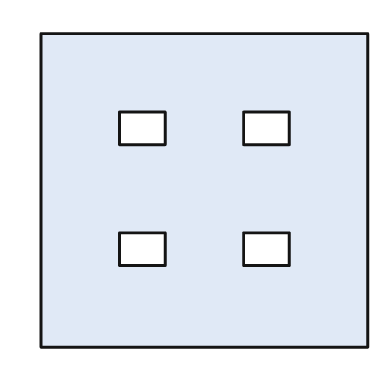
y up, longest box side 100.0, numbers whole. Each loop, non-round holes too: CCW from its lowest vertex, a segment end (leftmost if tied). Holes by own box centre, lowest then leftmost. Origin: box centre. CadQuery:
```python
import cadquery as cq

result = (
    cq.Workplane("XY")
    .moveTo(-50.0, -48.0)
    .lineTo(50.0, -48.0)
    .lineTo(50.0, 48.0)
    .lineTo(-50.0, 48.0)
    .close()
    .moveTo(-26.0, -23.0)
    .lineTo(-12.0, -23.0)
    .lineTo(-12.0, -13.0)
    .lineTo(-26.0, -13.0)
    .close()
    .moveTo(12.0, -23.0)
    .lineTo(26.0, -23.0)
    .lineTo(26.0, -13.0)
    .lineTo(12.0, -13.0)
    .close()
    .moveTo(-26.0, 14.0)
    .lineTo(-12.0, 14.0)
    .lineTo(-12.0, 24.0)
    .lineTo(-26.0, 24.0)
    .close()
    .moveTo(12.0, 14.0)
    .lineTo(26.0, 14.0)
    .lineTo(26.0, 24.0)
    .lineTo(12.0, 24.0)
    .close()
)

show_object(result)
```